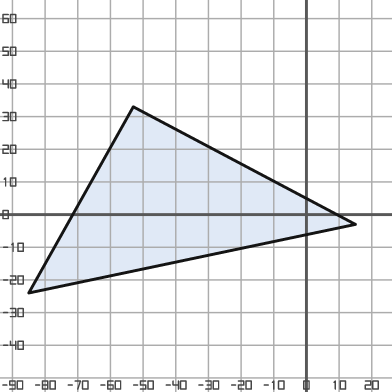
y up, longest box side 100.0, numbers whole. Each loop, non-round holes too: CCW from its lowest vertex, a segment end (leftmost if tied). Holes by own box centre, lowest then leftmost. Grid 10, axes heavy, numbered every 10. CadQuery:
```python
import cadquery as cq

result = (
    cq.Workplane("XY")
    .moveTo(-85.0, -24.0)
    .lineTo(15.0, -3.0)
    .lineTo(-53.0, 33.0)
    .close()
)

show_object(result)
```